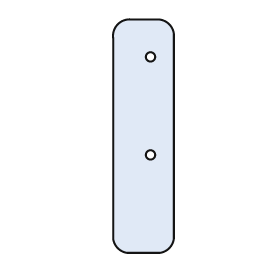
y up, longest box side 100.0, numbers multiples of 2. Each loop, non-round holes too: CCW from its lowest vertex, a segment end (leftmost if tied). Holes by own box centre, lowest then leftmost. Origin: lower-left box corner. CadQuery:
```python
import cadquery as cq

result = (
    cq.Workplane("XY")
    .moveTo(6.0, 0.0)
    .lineTo(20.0, 0.0)
    .threePointArc((24.0, 2.0), (26.0, 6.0))
    .lineTo(26.0, 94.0)
    .threePointArc((24.0, 98.0), (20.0, 100.0))
    .lineTo(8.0, 100.0)
    .threePointArc((2.0, 98.0), (0.0, 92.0))
    .lineTo(0.0, 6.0)
    .threePointArc((2.0, 2.0), (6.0, 0.0))
    .close()
    .moveTo(16.0, 42.0)
    .circle(2.0)
    .moveTo(16.0, 84.0)
    .circle(2.0)
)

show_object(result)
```